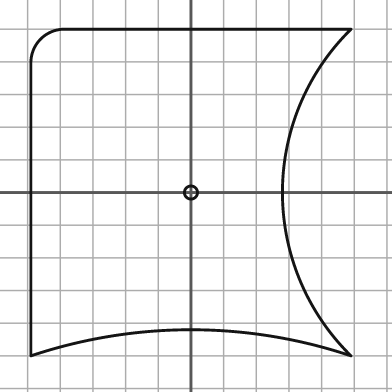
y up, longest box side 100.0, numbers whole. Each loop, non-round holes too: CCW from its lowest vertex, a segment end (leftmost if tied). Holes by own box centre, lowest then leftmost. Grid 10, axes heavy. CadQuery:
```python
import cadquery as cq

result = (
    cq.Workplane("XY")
    .moveTo(-49.0, -50.0)
    .threePointArc((0.0, -42.0), (49.0, -50.0))
    .threePointArc((28.0, 0.0), (49.0, 50.0))
    .lineTo(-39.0, 50.0)
    .threePointArc((-46.0, 47.0), (-49.0, 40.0))
    .close()
    .moveTo(0.0, 0.0)
    .circle(2.0)
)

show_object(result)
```